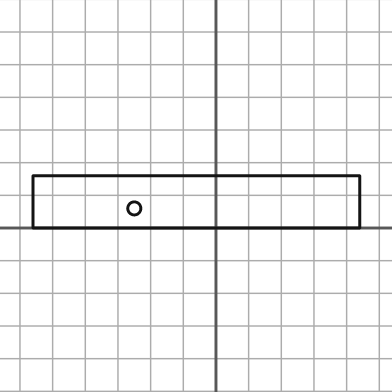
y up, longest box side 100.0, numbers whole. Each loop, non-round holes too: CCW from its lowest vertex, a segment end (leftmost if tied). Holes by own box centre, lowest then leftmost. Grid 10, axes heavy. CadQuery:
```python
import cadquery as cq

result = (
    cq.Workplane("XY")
    .moveTo(-56.0, 0.0)
    .lineTo(44.0, 0.0)
    .lineTo(44.0, 16.0)
    .lineTo(-56.0, 16.0)
    .close()
    .moveTo(-25.0, 6.0)
    .circle(2.0)
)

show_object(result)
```